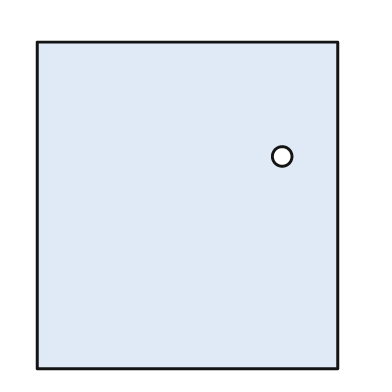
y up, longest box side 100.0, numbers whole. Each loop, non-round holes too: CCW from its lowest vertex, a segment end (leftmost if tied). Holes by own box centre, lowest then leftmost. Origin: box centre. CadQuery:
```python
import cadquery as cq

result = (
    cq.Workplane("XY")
    .moveTo(-46.0, -50.0)
    .lineTo(46.0, -50.0)
    .lineTo(46.0, 50.0)
    .lineTo(-46.0, 50.0)
    .close()
    .moveTo(29.0, 15.0)
    .circle(3.0)
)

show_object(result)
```